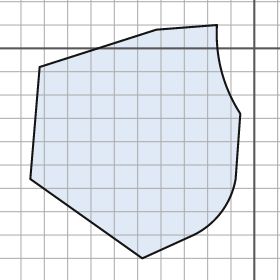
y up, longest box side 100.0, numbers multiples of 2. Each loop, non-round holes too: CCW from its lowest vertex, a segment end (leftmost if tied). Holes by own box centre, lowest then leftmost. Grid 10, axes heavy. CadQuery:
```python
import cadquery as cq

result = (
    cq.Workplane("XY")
    .moveTo(-48.0, -90.0)
    .lineTo(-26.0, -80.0)
    .threePointArc((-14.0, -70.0), (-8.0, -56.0))
    .lineTo(-6.0, -28.0)
    .threePointArc((-14.0, -10.0), (-16.0, 10.0))
    .lineTo(-42.0, 8.0)
    .lineTo(-92.0, -8.0)
    .lineTo(-96.0, -56.0)
    .close()
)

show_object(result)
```